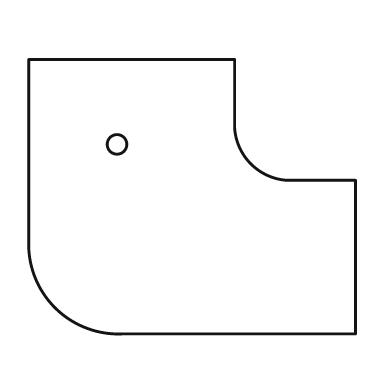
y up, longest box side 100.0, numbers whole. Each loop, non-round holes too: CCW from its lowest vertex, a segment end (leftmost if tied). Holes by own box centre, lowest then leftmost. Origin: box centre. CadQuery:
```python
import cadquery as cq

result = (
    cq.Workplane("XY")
    .moveTo(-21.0, -42.0)
    .lineTo(50.0, -42.0)
    .lineTo(50.0, 5.0)
    .lineTo(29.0, 5.0)
    .threePointArc((18.0, 10.0), (13.0, 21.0))
    .lineTo(13.0, 42.0)
    .lineTo(-50.0, 42.0)
    .lineTo(-50.0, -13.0)
    .threePointArc((-42.0, -34.0), (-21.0, -42.0))
    .close()
    .moveTo(-23.0, 16.0)
    .circle(3.0)
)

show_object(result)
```